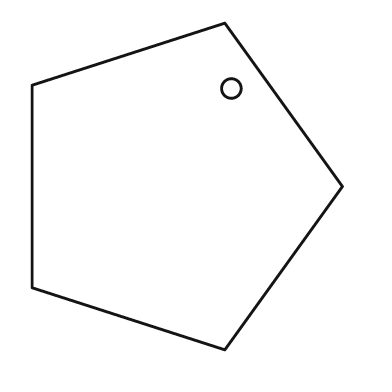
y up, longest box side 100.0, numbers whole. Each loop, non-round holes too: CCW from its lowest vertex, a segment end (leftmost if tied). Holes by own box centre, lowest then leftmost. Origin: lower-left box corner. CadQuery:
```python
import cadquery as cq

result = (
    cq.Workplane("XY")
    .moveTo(59.0, 0.0)
    .lineTo(95.0, 50.0)
    .lineTo(59.0, 100.0)
    .lineTo(0.0, 81.0)
    .lineTo(0.0, 19.0)
    .close()
    .moveTo(61.0, 80.0)
    .circle(3.0)
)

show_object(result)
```